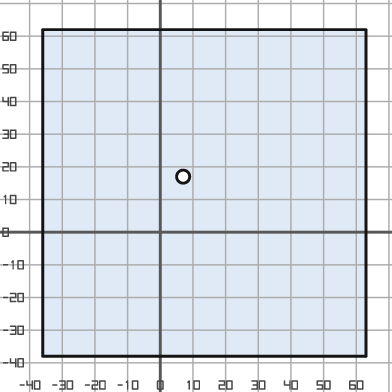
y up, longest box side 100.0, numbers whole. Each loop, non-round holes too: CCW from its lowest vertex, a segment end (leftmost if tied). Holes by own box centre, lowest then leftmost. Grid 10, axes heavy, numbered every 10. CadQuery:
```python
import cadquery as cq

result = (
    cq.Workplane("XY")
    .moveTo(-36.0, -38.0)
    .lineTo(63.0, -38.0)
    .lineTo(63.0, 62.0)
    .lineTo(-36.0, 62.0)
    .close()
    .moveTo(7.0, 17.0)
    .circle(2.0)
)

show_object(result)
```